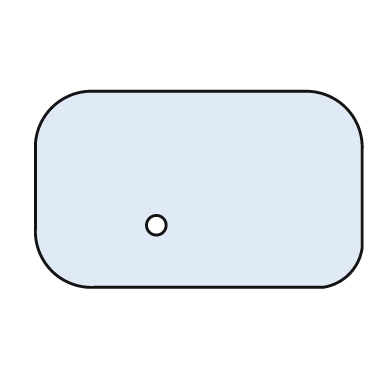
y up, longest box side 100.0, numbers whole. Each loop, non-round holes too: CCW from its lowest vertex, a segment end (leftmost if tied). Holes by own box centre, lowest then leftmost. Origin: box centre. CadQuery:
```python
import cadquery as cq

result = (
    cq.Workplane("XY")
    .moveTo(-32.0, -30.0)
    .lineTo(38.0, -30.0)
    .threePointArc((46.0, -26.0), (50.0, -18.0))
    .lineTo(50.0, 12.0)
    .threePointArc((45.0, 25.0), (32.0, 30.0))
    .lineTo(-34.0, 30.0)
    .threePointArc((-45.0, 25.0), (-50.0, 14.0))
    .lineTo(-50.0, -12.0)
    .threePointArc((-45.0, -25.0), (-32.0, -30.0))
    .close()
    .moveTo(-13.0, -11.0)
    .circle(3.0)
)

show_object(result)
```